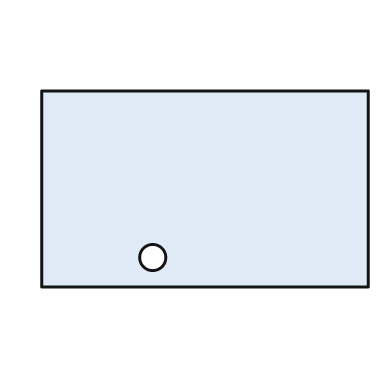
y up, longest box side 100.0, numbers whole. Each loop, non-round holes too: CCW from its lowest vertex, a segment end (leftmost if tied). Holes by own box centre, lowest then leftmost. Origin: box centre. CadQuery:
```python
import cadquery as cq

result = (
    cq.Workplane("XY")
    .moveTo(-50.0, -30.0)
    .lineTo(50.0, -30.0)
    .lineTo(50.0, 30.0)
    .lineTo(-50.0, 30.0)
    .close()
    .moveTo(-16.0, -21.0)
    .circle(4.0)
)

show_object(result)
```